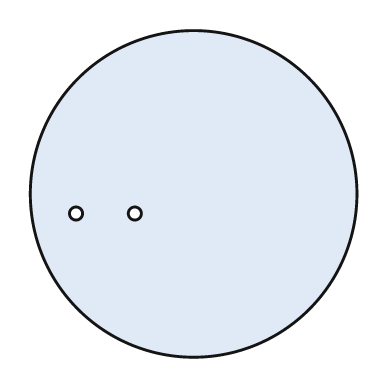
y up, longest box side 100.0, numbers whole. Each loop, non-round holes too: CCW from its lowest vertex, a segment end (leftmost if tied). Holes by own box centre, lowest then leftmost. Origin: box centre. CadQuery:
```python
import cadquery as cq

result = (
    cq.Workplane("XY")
    .moveTo(0.0, 0.0)
    .circle(50.0)
    .moveTo(-36.0, -6.0)
    .circle(2.0)
    .moveTo(-18.0, -6.0)
    .circle(2.0)
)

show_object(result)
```